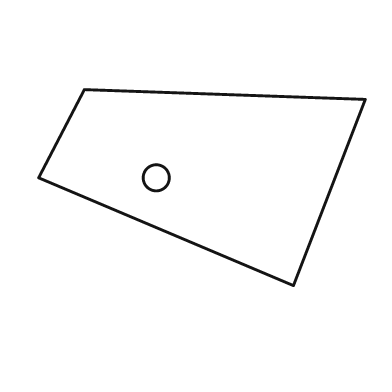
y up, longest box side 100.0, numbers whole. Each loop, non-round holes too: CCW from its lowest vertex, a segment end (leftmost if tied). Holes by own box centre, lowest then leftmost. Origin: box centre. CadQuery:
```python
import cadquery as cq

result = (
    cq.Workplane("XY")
    .moveTo(28.0, -30.0)
    .lineTo(50.0, 27.0)
    .lineTo(-36.0, 30.0)
    .lineTo(-50.0, 3.0)
    .close()
    .moveTo(-14.0, 3.0)
    .circle(4.0)
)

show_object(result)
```